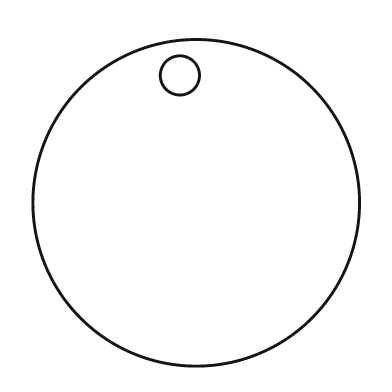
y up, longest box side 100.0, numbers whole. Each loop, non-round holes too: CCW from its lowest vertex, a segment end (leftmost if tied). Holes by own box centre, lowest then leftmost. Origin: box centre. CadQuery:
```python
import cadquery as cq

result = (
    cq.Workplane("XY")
    .moveTo(0.0, 0.0)
    .circle(50.0)
    .moveTo(-5.0, 39.0)
    .circle(6.0)
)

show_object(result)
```